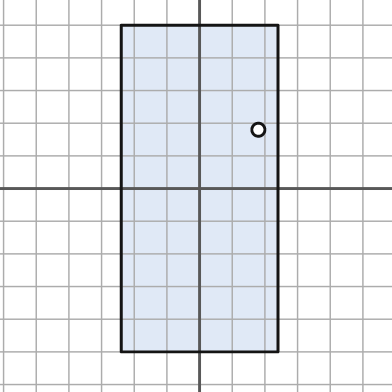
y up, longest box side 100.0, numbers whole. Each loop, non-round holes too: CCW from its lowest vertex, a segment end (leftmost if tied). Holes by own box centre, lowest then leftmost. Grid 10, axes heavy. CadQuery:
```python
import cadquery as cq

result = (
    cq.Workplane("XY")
    .moveTo(-24.0, -50.0)
    .lineTo(24.0, -50.0)
    .lineTo(24.0, 50.0)
    .lineTo(-24.0, 50.0)
    .close()
    .moveTo(18.0, 18.0)
    .circle(2.0)
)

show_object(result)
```